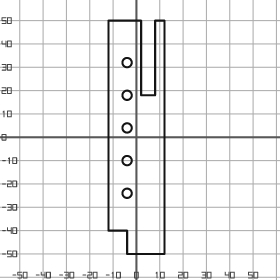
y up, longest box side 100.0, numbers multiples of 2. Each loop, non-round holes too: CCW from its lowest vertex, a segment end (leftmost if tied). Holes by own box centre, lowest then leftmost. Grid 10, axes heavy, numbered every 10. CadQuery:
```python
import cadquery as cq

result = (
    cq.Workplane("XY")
    .moveTo(-4.0, -50.0)
    .lineTo(12.0, -50.0)
    .lineTo(12.0, 50.0)
    .lineTo(8.0, 50.0)
    .lineTo(8.0, 18.0)
    .lineTo(2.0, 18.0)
    .lineTo(2.0, 50.0)
    .lineTo(-12.0, 50.0)
    .lineTo(-12.0, -40.0)
    .lineTo(-4.0, -40.0)
    .close()
    .moveTo(-4.0, -24.0)
    .circle(2.0)
    .moveTo(-4.0, -10.0)
    .circle(2.0)
    .moveTo(-4.0, 4.0)
    .circle(2.0)
    .moveTo(-4.0, 18.0)
    .circle(2.0)
    .moveTo(-4.0, 32.0)
    .circle(2.0)
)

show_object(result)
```